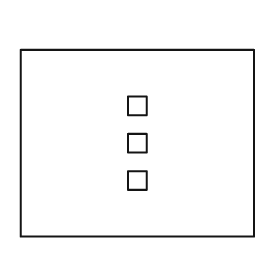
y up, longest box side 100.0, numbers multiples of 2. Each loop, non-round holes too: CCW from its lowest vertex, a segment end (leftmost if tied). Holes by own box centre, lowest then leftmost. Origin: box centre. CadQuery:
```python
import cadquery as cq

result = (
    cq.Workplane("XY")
    .moveTo(-50.0, -40.0)
    .lineTo(50.0, -40.0)
    .lineTo(50.0, 40.0)
    .lineTo(-50.0, 40.0)
    .close()
    .moveTo(-4.0, -20.0)
    .lineTo(4.0, -20.0)
    .lineTo(4.0, -12.0)
    .lineTo(-4.0, -12.0)
    .close()
    .moveTo(-4.0, -4.0)
    .lineTo(4.0, -4.0)
    .lineTo(4.0, 4.0)
    .lineTo(-4.0, 4.0)
    .close()
    .moveTo(-4.0, 12.0)
    .lineTo(4.0, 12.0)
    .lineTo(4.0, 20.0)
    .lineTo(-4.0, 20.0)
    .close()
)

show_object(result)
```